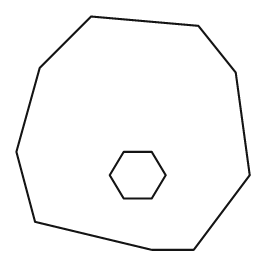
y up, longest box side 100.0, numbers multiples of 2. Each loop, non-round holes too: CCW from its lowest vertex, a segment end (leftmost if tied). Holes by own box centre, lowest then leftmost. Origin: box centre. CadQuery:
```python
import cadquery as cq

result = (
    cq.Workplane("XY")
    .moveTo(8.0, -50.0)
    .lineTo(26.0, -50.0)
    .lineTo(50.0, -18.0)
    .lineTo(44.0, 26.0)
    .lineTo(28.0, 46.0)
    .lineTo(-18.0, 50.0)
    .lineTo(-40.0, 28.0)
    .lineTo(-50.0, -8.0)
    .lineTo(-42.0, -38.0)
    .close()
    .moveTo(-4.0, -28.0)
    .lineTo(8.0, -28.0)
    .lineTo(14.0, -18.0)
    .lineTo(8.0, -8.0)
    .lineTo(-4.0, -8.0)
    .lineTo(-10.0, -18.0)
    .close()
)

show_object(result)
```